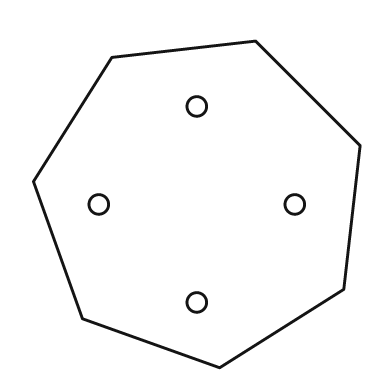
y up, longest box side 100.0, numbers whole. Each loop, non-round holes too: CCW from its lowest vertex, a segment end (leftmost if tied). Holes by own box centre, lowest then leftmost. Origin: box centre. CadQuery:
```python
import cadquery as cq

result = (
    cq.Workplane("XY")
    .moveTo(7.0, -50.0)
    .lineTo(45.0, -26.0)
    .lineTo(50.0, 18.0)
    .lineTo(18.0, 50.0)
    .lineTo(-26.0, 45.0)
    .lineTo(-50.0, 7.0)
    .lineTo(-35.0, -35.0)
    .close()
    .moveTo(0.0, -30.0)
    .circle(3.0)
    .moveTo(-30.0, 0.0)
    .circle(3.0)
    .moveTo(30.0, 0.0)
    .circle(3.0)
    .moveTo(0.0, 30.0)
    .circle(3.0)
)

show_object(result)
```